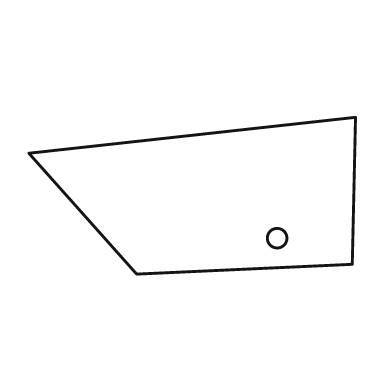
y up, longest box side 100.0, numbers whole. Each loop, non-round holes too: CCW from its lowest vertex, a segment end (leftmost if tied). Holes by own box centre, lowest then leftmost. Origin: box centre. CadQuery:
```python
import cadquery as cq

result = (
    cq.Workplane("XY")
    .moveTo(-17.0, -24.0)
    .lineTo(49.0, -21.0)
    .lineTo(50.0, 24.0)
    .lineTo(-50.0, 13.0)
    .close()
    .moveTo(26.0, -13.0)
    .circle(3.0)
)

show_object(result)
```